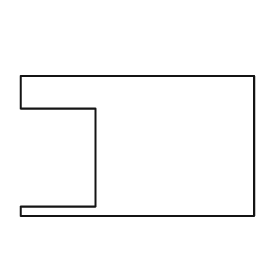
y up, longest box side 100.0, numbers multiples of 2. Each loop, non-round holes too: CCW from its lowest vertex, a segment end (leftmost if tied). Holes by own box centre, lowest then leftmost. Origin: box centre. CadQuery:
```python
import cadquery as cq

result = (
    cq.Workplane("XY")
    .moveTo(-50.0, -30.0)
    .lineTo(50.0, -30.0)
    .lineTo(50.0, 30.0)
    .lineTo(-50.0, 30.0)
    .lineTo(-50.0, 16.0)
    .lineTo(-18.0, 16.0)
    .lineTo(-18.0, -26.0)
    .lineTo(-50.0, -26.0)
    .close()
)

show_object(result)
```